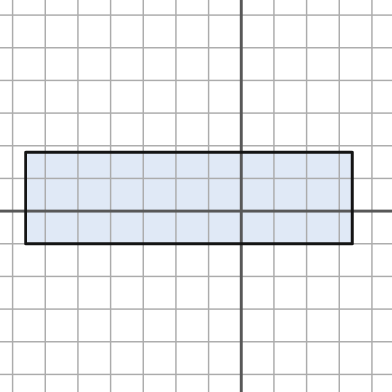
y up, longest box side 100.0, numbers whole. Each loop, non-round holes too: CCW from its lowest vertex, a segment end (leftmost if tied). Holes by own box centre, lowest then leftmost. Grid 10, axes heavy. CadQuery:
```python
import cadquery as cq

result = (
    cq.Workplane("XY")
    .moveTo(-66.0, -10.0)
    .lineTo(34.0, -10.0)
    .lineTo(34.0, 18.0)
    .lineTo(-66.0, 18.0)
    .close()
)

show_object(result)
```